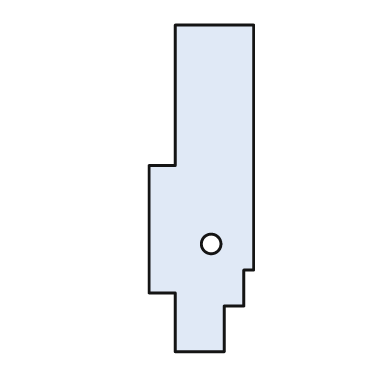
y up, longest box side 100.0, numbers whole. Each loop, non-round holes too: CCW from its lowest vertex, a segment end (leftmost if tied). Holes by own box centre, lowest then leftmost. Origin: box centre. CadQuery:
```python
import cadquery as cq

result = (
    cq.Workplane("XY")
    .moveTo(-8.0, -50.0)
    .lineTo(7.0, -50.0)
    .lineTo(7.0, -36.0)
    .lineTo(13.0, -36.0)
    .lineTo(13.0, -25.0)
    .lineTo(16.0, -25.0)
    .lineTo(16.0, 50.0)
    .lineTo(-8.0, 50.0)
    .lineTo(-8.0, 7.0)
    .lineTo(-16.0, 7.0)
    .lineTo(-16.0, -32.0)
    .lineTo(-8.0, -32.0)
    .close()
    .moveTo(3.0, -17.0)
    .circle(3.0)
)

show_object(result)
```